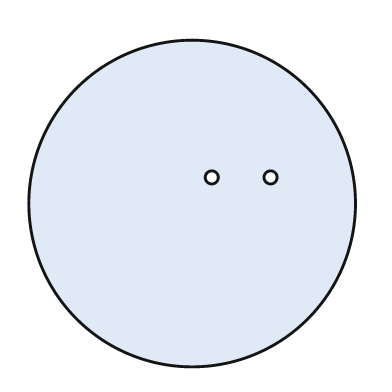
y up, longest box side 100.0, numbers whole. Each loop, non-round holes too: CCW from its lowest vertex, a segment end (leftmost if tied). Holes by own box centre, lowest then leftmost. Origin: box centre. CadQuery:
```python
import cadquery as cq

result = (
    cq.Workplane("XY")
    .moveTo(0.0, 0.0)
    .circle(50.0)
    .moveTo(6.0, 8.0)
    .circle(2.0)
    .moveTo(24.0, 8.0)
    .circle(2.0)
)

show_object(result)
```